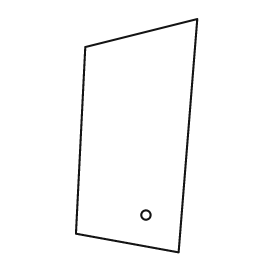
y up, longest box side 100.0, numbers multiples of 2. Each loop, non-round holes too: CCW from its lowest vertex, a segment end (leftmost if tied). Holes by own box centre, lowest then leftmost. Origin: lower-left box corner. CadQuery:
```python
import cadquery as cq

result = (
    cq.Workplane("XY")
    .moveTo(44.0, 0.0)
    .lineTo(52.0, 100.0)
    .lineTo(4.0, 88.0)
    .lineTo(0.0, 8.0)
    .close()
    .moveTo(30.0, 16.0)
    .circle(2.0)
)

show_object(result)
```